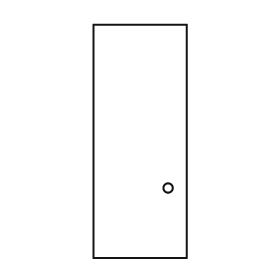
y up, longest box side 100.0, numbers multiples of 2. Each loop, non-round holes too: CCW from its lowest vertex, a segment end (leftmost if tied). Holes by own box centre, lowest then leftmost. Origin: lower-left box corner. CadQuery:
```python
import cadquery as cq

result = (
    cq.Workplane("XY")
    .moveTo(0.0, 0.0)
    .lineTo(40.0, 0.0)
    .lineTo(40.0, 100.0)
    .lineTo(0.0, 100.0)
    .close()
    .moveTo(32.0, 30.0)
    .circle(2.0)
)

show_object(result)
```